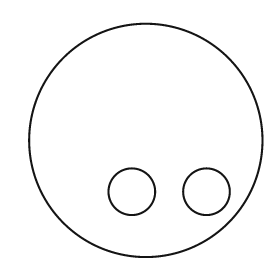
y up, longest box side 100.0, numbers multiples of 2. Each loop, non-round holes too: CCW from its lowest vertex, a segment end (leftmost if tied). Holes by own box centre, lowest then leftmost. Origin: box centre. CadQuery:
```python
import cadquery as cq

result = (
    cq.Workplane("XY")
    .moveTo(0.0, 0.0)
    .circle(50.0)
    .moveTo(-6.0, -22.0)
    .circle(10.0)
    .moveTo(26.0, -22.0)
    .circle(10.0)
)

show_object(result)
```